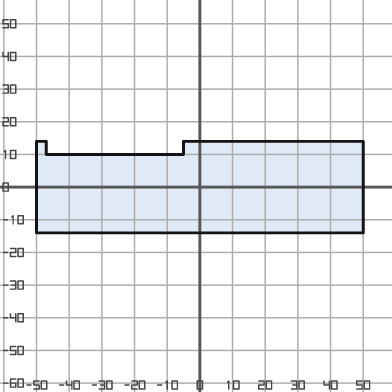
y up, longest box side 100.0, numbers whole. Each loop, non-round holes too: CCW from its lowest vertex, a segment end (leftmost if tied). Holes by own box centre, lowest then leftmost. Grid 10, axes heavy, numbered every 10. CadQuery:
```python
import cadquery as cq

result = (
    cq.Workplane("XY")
    .moveTo(-50.0, -14.0)
    .lineTo(50.0, -14.0)
    .lineTo(50.0, 14.0)
    .lineTo(-5.0, 14.0)
    .lineTo(-5.0, 10.0)
    .lineTo(-47.0, 10.0)
    .lineTo(-47.0, 14.0)
    .lineTo(-50.0, 14.0)
    .close()
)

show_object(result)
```